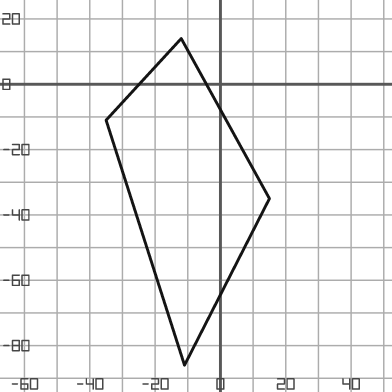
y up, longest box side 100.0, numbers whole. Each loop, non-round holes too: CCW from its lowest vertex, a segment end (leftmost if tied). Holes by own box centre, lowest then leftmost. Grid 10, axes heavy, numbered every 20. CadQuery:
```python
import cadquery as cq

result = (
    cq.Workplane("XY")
    .moveTo(-11.0, -86.0)
    .lineTo(15.0, -35.0)
    .lineTo(-12.0, 14.0)
    .lineTo(-35.0, -11.0)
    .close()
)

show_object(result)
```